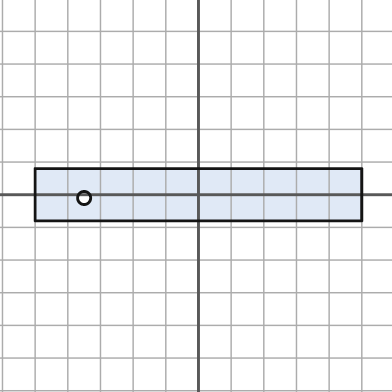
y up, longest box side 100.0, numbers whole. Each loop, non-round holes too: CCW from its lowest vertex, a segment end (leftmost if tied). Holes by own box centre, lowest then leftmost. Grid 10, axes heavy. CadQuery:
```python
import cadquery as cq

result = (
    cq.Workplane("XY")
    .moveTo(-50.0, -8.0)
    .lineTo(50.0, -8.0)
    .lineTo(50.0, 8.0)
    .lineTo(-50.0, 8.0)
    .close()
    .moveTo(-35.0, -1.0)
    .circle(2.0)
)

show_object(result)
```